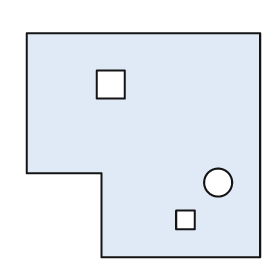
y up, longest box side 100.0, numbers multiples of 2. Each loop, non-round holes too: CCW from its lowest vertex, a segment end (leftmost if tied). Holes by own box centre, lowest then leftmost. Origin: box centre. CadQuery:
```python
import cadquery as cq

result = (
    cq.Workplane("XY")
    .moveTo(-18.0, -48.0)
    .lineTo(50.0, -48.0)
    .lineTo(50.0, 48.0)
    .lineTo(-50.0, 48.0)
    .lineTo(-50.0, -12.0)
    .lineTo(-18.0, -12.0)
    .close()
    .moveTo(14.0, -36.0)
    .lineTo(22.0, -36.0)
    .lineTo(22.0, -28.0)
    .lineTo(14.0, -28.0)
    .close()
    .moveTo(32.0, -16.0)
    .circle(6.0)
    .moveTo(-20.0, 20.0)
    .lineTo(-8.0, 20.0)
    .lineTo(-8.0, 32.0)
    .lineTo(-20.0, 32.0)
    .close()
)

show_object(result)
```